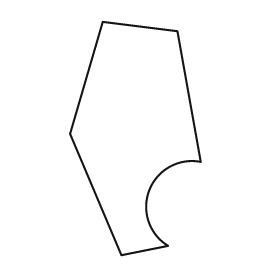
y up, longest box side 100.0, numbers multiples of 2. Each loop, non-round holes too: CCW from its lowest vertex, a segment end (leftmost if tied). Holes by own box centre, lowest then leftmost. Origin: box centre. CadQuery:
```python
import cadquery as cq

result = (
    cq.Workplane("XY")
    .moveTo(-6.0, -50.0)
    .lineTo(14.0, -46.0)
    .threePointArc((6.0, -22.0), (28.0, -10.0))
    .lineTo(18.0, 46.0)
    .lineTo(-14.0, 50.0)
    .lineTo(-28.0, 2.0)
    .close()
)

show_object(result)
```